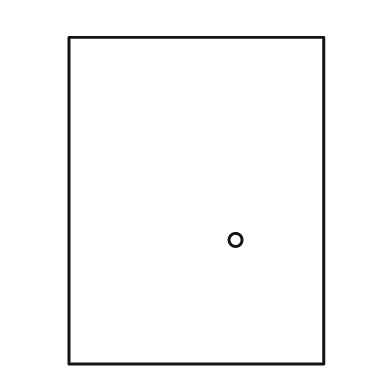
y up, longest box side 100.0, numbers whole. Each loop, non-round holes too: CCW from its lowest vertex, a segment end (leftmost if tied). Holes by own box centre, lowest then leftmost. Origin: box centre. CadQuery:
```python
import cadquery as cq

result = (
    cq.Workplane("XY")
    .moveTo(-39.0, -50.0)
    .lineTo(39.0, -50.0)
    .lineTo(39.0, 50.0)
    .lineTo(-39.0, 50.0)
    .close()
    .moveTo(12.0, -12.0)
    .circle(2.0)
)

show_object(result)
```